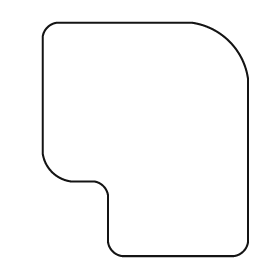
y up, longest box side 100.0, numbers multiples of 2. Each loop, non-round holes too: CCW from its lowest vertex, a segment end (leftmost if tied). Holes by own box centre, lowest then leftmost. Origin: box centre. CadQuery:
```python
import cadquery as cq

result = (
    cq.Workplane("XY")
    .moveTo(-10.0, -50.0)
    .lineTo(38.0, -50.0)
    .threePointArc((42.0, -48.0), (44.0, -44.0))
    .lineTo(44.0, 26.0)
    .threePointArc((36.0, 42.0), (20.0, 50.0))
    .lineTo(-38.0, 50.0)
    .threePointArc((-42.0, 48.0), (-44.0, 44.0))
    .lineTo(-44.0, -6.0)
    .threePointArc((-40.0, -14.0), (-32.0, -18.0))
    .lineTo(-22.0, -18.0)
    .threePointArc((-18.0, -20.0), (-16.0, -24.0))
    .lineTo(-16.0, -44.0)
    .threePointArc((-14.0, -48.0), (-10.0, -50.0))
    .close()
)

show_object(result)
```